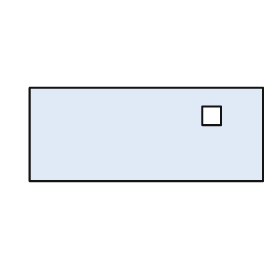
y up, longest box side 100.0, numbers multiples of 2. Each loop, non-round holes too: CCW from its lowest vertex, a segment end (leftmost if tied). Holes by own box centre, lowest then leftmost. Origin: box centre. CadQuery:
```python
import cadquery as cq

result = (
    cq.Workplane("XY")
    .moveTo(-50.0, -20.0)
    .lineTo(50.0, -20.0)
    .lineTo(50.0, 20.0)
    .lineTo(-50.0, 20.0)
    .close()
    .moveTo(24.0, 4.0)
    .lineTo(32.0, 4.0)
    .lineTo(32.0, 12.0)
    .lineTo(24.0, 12.0)
    .close()
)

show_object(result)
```